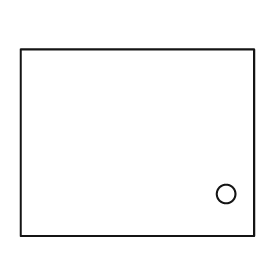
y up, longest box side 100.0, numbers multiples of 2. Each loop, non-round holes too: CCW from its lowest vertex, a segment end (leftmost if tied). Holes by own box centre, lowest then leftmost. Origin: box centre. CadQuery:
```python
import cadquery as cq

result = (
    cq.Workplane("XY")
    .moveTo(-50.0, -40.0)
    .lineTo(50.0, -40.0)
    .lineTo(50.0, 40.0)
    .lineTo(-50.0, 40.0)
    .close()
    .moveTo(38.0, -22.0)
    .circle(4.0)
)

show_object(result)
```